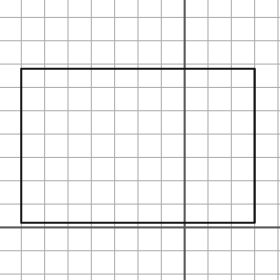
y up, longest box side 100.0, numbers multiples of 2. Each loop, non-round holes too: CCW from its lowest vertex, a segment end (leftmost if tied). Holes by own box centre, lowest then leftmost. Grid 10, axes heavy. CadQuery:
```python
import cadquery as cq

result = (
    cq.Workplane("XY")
    .moveTo(-70.0, 2.0)
    .lineTo(30.0, 2.0)
    .lineTo(30.0, 68.0)
    .lineTo(-70.0, 68.0)
    .close()
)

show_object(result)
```